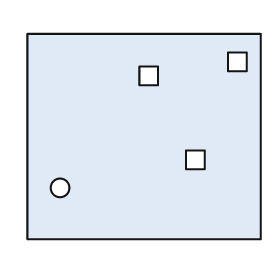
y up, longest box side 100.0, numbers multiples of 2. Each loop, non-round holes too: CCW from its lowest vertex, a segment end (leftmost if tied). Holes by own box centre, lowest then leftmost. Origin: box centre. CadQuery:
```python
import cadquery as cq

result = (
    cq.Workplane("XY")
    .moveTo(-50.0, -44.0)
    .lineTo(50.0, -44.0)
    .lineTo(50.0, 44.0)
    .lineTo(-50.0, 44.0)
    .close()
    .moveTo(-36.0, -22.0)
    .circle(4.0)
    .moveTo(18.0, -14.0)
    .lineTo(26.0, -14.0)
    .lineTo(26.0, -6.0)
    .lineTo(18.0, -6.0)
    .close()
    .moveTo(-2.0, 22.0)
    .lineTo(6.0, 22.0)
    .lineTo(6.0, 30.0)
    .lineTo(-2.0, 30.0)
    .close()
    .moveTo(36.0, 28.0)
    .lineTo(44.0, 28.0)
    .lineTo(44.0, 36.0)
    .lineTo(36.0, 36.0)
    .close()
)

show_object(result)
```